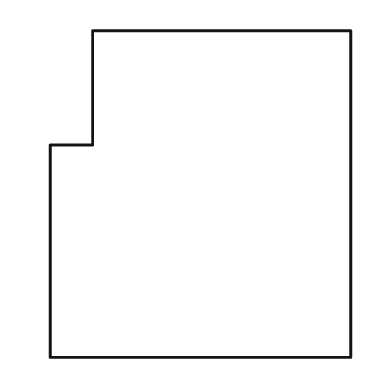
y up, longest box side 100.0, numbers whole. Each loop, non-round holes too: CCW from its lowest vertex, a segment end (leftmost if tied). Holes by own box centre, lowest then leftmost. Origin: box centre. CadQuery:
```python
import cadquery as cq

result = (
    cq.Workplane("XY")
    .moveTo(-46.0, -50.0)
    .lineTo(46.0, -50.0)
    .lineTo(46.0, 50.0)
    .lineTo(-33.0, 50.0)
    .lineTo(-33.0, 15.0)
    .lineTo(-46.0, 15.0)
    .close()
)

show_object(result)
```